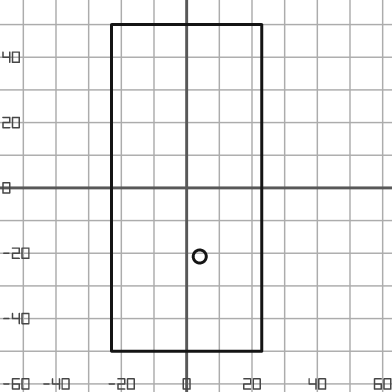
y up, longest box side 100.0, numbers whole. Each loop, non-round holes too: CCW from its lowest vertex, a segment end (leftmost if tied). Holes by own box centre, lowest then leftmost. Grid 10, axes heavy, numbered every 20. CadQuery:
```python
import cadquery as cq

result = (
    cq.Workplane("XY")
    .moveTo(-23.0, -50.0)
    .lineTo(23.0, -50.0)
    .lineTo(23.0, 50.0)
    .lineTo(-23.0, 50.0)
    .close()
    .moveTo(4.0, -21.0)
    .circle(2.0)
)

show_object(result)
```